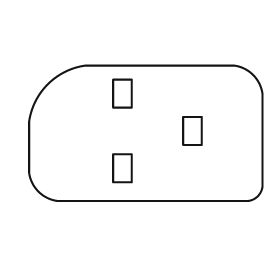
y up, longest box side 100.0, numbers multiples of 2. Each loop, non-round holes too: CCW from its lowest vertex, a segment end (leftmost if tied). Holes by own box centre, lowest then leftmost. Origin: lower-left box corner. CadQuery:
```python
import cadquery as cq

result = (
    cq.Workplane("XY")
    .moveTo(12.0, 0.0)
    .lineTo(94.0, 0.0)
    .threePointArc((98.0, 2.0), (100.0, 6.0))
    .lineTo(100.0, 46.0)
    .threePointArc((96.0, 54.0), (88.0, 58.0))
    .lineTo(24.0, 58.0)
    .threePointArc((8.0, 50.0), (0.0, 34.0))
    .lineTo(0.0, 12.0)
    .threePointArc((4.0, 4.0), (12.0, 0.0))
    .close()
    .moveTo(36.0, 8.0)
    .lineTo(44.0, 8.0)
    .lineTo(44.0, 20.0)
    .lineTo(36.0, 20.0)
    .close()
    .moveTo(66.0, 24.0)
    .lineTo(74.0, 24.0)
    .lineTo(74.0, 36.0)
    .lineTo(66.0, 36.0)
    .close()
    .moveTo(36.0, 40.0)
    .lineTo(44.0, 40.0)
    .lineTo(44.0, 52.0)
    .lineTo(36.0, 52.0)
    .close()
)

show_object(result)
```